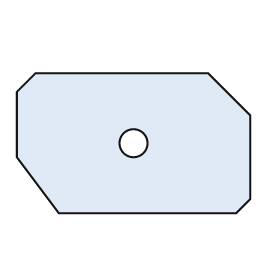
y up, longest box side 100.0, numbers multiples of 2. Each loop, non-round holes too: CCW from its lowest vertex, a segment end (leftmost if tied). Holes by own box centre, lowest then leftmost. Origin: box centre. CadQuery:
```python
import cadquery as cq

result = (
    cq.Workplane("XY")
    .moveTo(-32.0, -30.0)
    .lineTo(44.0, -30.0)
    .lineTo(50.0, -24.0)
    .lineTo(50.0, 12.0)
    .lineTo(32.0, 30.0)
    .lineTo(-42.0, 30.0)
    .lineTo(-50.0, 22.0)
    .lineTo(-50.0, -6.0)
    .close()
    .moveTo(0.0, 0.0)
    .circle(6.0)
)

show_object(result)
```